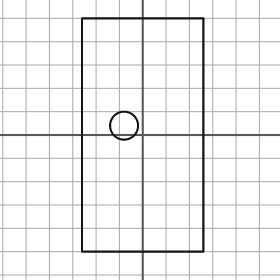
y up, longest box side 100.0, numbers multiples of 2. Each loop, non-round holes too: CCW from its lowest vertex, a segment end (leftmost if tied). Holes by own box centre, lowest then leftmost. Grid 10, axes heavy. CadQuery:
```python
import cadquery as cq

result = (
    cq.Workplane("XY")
    .moveTo(-26.0, -50.0)
    .lineTo(26.0, -50.0)
    .lineTo(26.0, 50.0)
    .lineTo(-26.0, 50.0)
    .close()
    .moveTo(-8.0, 4.0)
    .circle(6.0)
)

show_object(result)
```